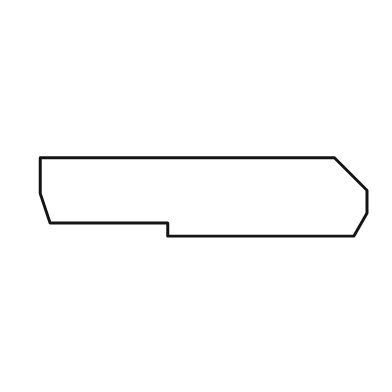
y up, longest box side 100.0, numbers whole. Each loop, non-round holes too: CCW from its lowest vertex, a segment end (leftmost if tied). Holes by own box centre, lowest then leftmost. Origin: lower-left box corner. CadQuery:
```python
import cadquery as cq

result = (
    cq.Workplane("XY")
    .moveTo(39.0, 0.0)
    .lineTo(96.0, 0.0)
    .lineTo(100.0, 7.0)
    .lineTo(100.0, 14.0)
    .lineTo(90.0, 24.0)
    .lineTo(0.0, 24.0)
    .lineTo(0.0, 13.0)
    .lineTo(3.0, 4.0)
    .lineTo(39.0, 4.0)
    .close()
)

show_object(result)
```